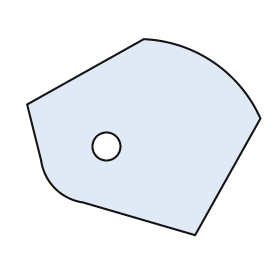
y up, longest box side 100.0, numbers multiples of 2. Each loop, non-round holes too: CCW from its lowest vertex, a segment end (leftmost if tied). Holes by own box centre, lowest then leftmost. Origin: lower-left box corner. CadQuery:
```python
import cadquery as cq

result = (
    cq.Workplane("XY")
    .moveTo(72.0, 0.0)
    .lineTo(100.0, 50.0)
    .threePointArc((80.0, 74.0), (50.0, 84.0))
    .lineTo(0.0, 56.0)
    .lineTo(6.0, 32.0)
    .threePointArc((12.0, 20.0), (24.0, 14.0))
    .close()
    .moveTo(34.0, 38.0)
    .circle(6.0)
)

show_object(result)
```